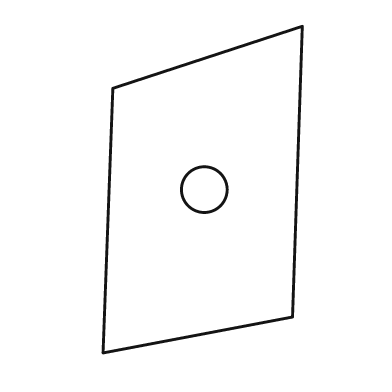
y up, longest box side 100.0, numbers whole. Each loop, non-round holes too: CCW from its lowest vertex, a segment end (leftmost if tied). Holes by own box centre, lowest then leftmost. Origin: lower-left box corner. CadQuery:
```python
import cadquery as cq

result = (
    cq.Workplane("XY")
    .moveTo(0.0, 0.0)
    .lineTo(58.0, 11.0)
    .lineTo(61.0, 100.0)
    .lineTo(3.0, 81.0)
    .close()
    .moveTo(31.0, 50.0)
    .circle(7.0)
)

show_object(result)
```